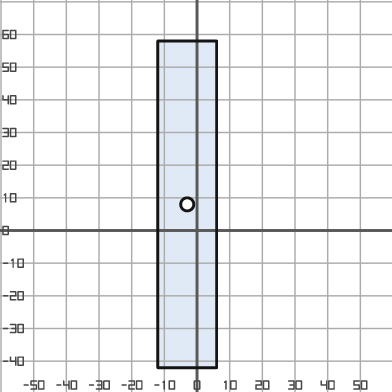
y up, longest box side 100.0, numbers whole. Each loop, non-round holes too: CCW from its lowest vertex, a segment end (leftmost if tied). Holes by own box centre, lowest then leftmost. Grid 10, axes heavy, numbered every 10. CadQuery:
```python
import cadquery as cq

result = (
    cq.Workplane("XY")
    .moveTo(-12.0, -42.0)
    .lineTo(6.0, -42.0)
    .lineTo(6.0, 58.0)
    .lineTo(-12.0, 58.0)
    .close()
    .moveTo(-3.0, 8.0)
    .circle(2.0)
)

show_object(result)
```